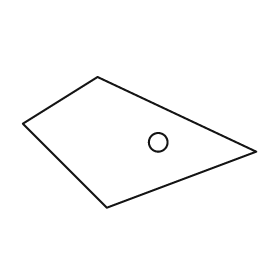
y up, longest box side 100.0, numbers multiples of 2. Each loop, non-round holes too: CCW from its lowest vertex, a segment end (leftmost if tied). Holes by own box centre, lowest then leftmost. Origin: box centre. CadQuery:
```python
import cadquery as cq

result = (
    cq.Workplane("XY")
    .moveTo(-14.0, -28.0)
    .lineTo(50.0, -4.0)
    .lineTo(-18.0, 28.0)
    .lineTo(-50.0, 8.0)
    .close()
    .moveTo(8.0, 0.0)
    .circle(4.0)
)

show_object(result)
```